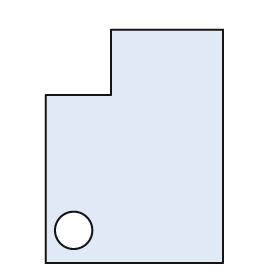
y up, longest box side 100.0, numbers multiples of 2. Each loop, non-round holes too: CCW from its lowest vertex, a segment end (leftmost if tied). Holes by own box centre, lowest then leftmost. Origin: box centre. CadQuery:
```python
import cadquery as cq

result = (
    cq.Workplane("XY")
    .moveTo(-38.0, -50.0)
    .lineTo(38.0, -50.0)
    .lineTo(38.0, 50.0)
    .lineTo(-10.0, 50.0)
    .lineTo(-10.0, 22.0)
    .lineTo(-38.0, 22.0)
    .close()
    .moveTo(-26.0, -36.0)
    .circle(8.0)
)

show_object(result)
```